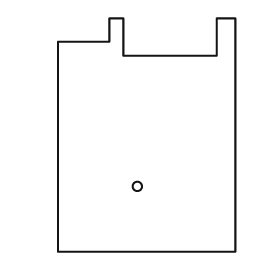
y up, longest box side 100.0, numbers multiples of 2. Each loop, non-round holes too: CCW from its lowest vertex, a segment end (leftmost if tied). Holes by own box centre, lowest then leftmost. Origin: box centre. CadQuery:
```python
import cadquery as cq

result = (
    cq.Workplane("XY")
    .moveTo(-38.0, -50.0)
    .lineTo(38.0, -50.0)
    .lineTo(38.0, 50.0)
    .lineTo(30.0, 50.0)
    .lineTo(30.0, 34.0)
    .lineTo(-10.0, 34.0)
    .lineTo(-10.0, 50.0)
    .lineTo(-16.0, 50.0)
    .lineTo(-16.0, 40.0)
    .lineTo(-38.0, 40.0)
    .close()
    .moveTo(-4.0, -22.0)
    .circle(2.0)
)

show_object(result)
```